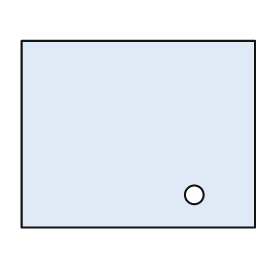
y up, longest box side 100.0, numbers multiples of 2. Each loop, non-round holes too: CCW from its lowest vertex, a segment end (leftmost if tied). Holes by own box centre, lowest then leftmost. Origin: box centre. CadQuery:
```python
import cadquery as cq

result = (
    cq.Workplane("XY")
    .moveTo(-50.0, -40.0)
    .lineTo(50.0, -40.0)
    .lineTo(50.0, 40.0)
    .lineTo(-50.0, 40.0)
    .close()
    .moveTo(24.0, -26.0)
    .circle(4.0)
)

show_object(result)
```